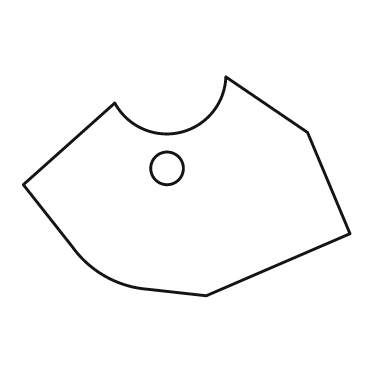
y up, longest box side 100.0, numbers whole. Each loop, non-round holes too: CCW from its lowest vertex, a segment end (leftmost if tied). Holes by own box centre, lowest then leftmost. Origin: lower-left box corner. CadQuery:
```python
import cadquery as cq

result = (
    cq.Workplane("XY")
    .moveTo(56.0, 0.0)
    .lineTo(100.0, 19.0)
    .lineTo(87.0, 50.0)
    .lineTo(62.0, 67.0)
    .threePointArc((48.0, 50.0), (28.0, 59.0))
    .lineTo(0.0, 34.0)
    .lineTo(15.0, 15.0)
    .threePointArc((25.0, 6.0), (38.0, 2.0))
    .close()
    .moveTo(44.0, 39.0)
    .circle(5.0)
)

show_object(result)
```